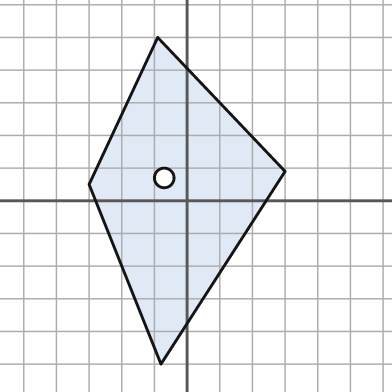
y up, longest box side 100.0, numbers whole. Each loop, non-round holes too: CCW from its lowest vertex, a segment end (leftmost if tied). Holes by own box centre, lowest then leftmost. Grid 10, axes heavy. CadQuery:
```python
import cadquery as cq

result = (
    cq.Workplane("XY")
    .moveTo(-8.0, -50.0)
    .lineTo(30.0, 9.0)
    .lineTo(-9.0, 50.0)
    .lineTo(-30.0, 5.0)
    .close()
    .moveTo(-7.0, 7.0)
    .circle(3.0)
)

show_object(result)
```